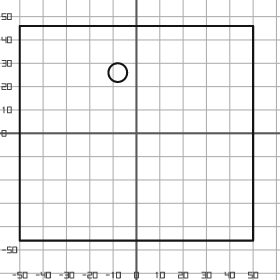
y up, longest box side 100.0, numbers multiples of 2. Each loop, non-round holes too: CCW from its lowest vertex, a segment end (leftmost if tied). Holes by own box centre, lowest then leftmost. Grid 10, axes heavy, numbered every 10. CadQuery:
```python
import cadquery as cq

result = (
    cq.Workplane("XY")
    .moveTo(-50.0, -46.0)
    .lineTo(50.0, -46.0)
    .lineTo(50.0, 46.0)
    .lineTo(-50.0, 46.0)
    .close()
    .moveTo(-8.0, 26.0)
    .circle(4.0)
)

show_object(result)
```